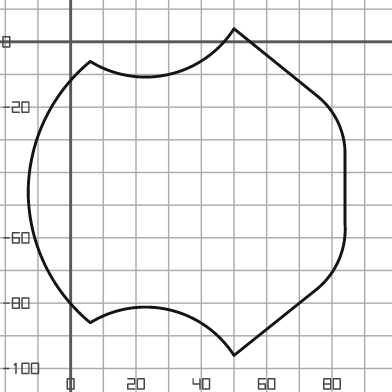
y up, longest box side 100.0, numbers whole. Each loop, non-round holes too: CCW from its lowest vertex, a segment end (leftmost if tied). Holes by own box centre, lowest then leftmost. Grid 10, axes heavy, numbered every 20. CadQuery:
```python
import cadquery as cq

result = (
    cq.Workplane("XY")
    .moveTo(50.0, -96.0)
    .lineTo(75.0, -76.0)
    .threePointArc((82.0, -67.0), (84.0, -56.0))
    .lineTo(84.0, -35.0)
    .threePointArc((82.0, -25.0), (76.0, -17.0))
    .lineTo(50.0, 4.0)
    .threePointArc((30.0, -10.0), (6.0, -6.0))
    .threePointArc((-8.0, -24.0), (-13.0, -46.0))
    .threePointArc((-8.0, -68.0), (6.0, -86.0))
    .threePointArc((30.0, -82.0), (50.0, -96.0))
    .close()
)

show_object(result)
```